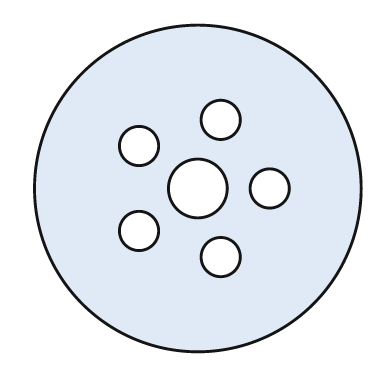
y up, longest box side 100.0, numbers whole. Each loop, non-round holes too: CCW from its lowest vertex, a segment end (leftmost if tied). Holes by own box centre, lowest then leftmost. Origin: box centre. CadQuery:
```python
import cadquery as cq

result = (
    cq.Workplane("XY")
    .moveTo(0.0, 0.0)
    .circle(50.0)
    .moveTo(7.0, -21.0)
    .circle(6.0)
    .moveTo(-18.0, -13.0)
    .circle(6.0)
    .moveTo(0.0, 0.0)
    .circle(9.0)
    .moveTo(22.0, 0.0)
    .circle(6.0)
    .moveTo(-18.0, 13.0)
    .circle(6.0)
    .moveTo(7.0, 21.0)
    .circle(6.0)
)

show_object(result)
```